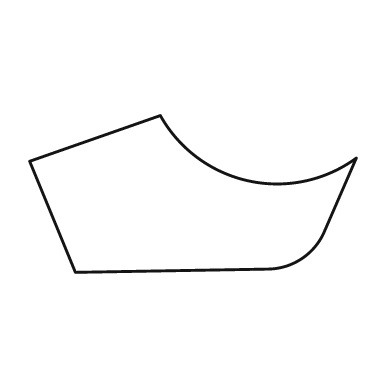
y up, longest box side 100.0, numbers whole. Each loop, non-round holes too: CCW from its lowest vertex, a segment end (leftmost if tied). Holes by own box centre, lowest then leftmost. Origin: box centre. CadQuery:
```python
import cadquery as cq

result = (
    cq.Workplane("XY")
    .moveTo(-36.0, -24.0)
    .lineTo(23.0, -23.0)
    .threePointArc((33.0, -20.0), (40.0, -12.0))
    .lineTo(50.0, 11.0)
    .threePointArc((17.0, 4.0), (-10.0, 24.0))
    .lineTo(-50.0, 10.0)
    .close()
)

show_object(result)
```